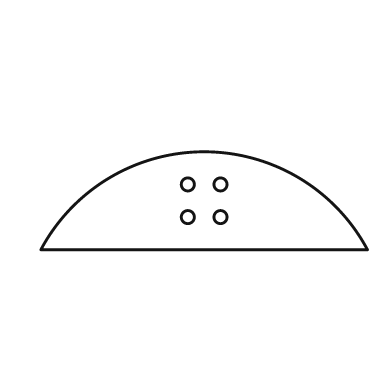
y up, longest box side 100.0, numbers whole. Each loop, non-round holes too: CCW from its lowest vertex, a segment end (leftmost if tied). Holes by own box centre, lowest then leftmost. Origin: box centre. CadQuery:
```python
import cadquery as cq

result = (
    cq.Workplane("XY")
    .moveTo(-50.0, -15.0)
    .lineTo(50.0, -15.0)
    .threePointArc((0.0, 15.0), (-50.0, -15.0))
    .close()
    .moveTo(-5.0, -5.0)
    .circle(2.0)
    .moveTo(5.0, -5.0)
    .circle(2.0)
    .moveTo(-5.0, 5.0)
    .circle(2.0)
    .moveTo(5.0, 5.0)
    .circle(2.0)
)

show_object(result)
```